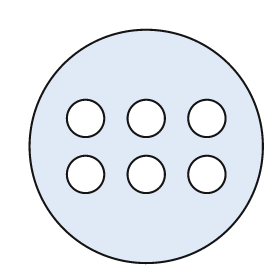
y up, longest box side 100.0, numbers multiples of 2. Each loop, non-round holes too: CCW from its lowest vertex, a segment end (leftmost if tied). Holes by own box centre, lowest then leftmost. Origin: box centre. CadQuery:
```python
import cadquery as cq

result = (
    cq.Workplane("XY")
    .moveTo(0.0, 0.0)
    .circle(50.0)
    .moveTo(-26.0, -12.0)
    .circle(8.0)
    .moveTo(0.0, -12.0)
    .circle(8.0)
    .moveTo(26.0, -12.0)
    .circle(8.0)
    .moveTo(-26.0, 12.0)
    .circle(8.0)
    .moveTo(0.0, 12.0)
    .circle(8.0)
    .moveTo(26.0, 12.0)
    .circle(8.0)
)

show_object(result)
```